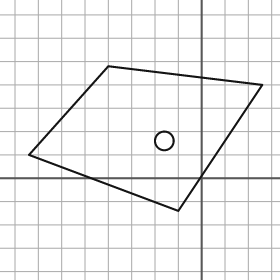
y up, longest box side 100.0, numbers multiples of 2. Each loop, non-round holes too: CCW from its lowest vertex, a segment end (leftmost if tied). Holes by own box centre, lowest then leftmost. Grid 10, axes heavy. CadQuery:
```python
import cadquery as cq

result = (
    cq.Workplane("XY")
    .moveTo(-10.0, -14.0)
    .lineTo(26.0, 40.0)
    .lineTo(-40.0, 48.0)
    .lineTo(-74.0, 10.0)
    .close()
    .moveTo(-16.0, 16.0)
    .circle(4.0)
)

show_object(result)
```